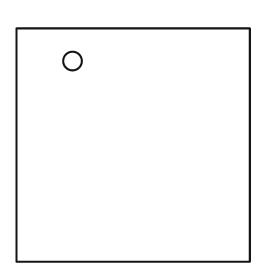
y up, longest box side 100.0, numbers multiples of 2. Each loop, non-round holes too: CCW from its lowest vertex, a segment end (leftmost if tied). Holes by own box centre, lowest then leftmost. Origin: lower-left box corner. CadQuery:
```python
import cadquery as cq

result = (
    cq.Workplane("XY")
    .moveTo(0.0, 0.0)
    .lineTo(100.0, 0.0)
    .lineTo(100.0, 100.0)
    .lineTo(0.0, 100.0)
    .close()
    .moveTo(24.0, 86.0)
    .circle(4.0)
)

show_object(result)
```